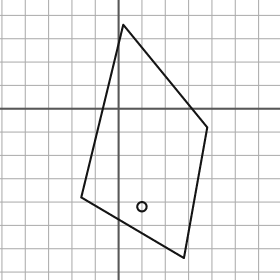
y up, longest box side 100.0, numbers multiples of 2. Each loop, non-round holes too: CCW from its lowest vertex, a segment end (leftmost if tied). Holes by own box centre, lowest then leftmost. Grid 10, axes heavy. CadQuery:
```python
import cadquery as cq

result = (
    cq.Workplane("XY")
    .moveTo(28.0, -64.0)
    .lineTo(38.0, -8.0)
    .lineTo(2.0, 36.0)
    .lineTo(-16.0, -38.0)
    .close()
    .moveTo(10.0, -42.0)
    .circle(2.0)
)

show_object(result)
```